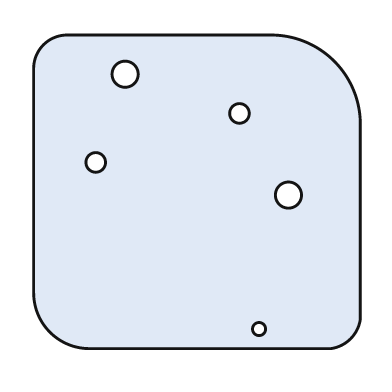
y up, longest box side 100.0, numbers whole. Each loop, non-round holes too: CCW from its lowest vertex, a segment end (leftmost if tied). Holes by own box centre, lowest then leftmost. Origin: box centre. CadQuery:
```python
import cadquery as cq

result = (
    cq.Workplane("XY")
    .moveTo(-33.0, -48.0)
    .lineTo(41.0, -48.0)
    .threePointArc((47.0, -45.0), (50.0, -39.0))
    .lineTo(50.0, 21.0)
    .threePointArc((42.0, 40.0), (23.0, 48.0))
    .lineTo(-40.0, 48.0)
    .threePointArc((-47.0, 45.0), (-50.0, 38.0))
    .lineTo(-50.0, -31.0)
    .threePointArc((-45.0, -43.0), (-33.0, -48.0))
    .close()
    .moveTo(19.0, -42.0)
    .circle(2.0)
    .moveTo(28.0, -1.0)
    .circle(4.0)
    .moveTo(-31.0, 9.0)
    .circle(3.0)
    .moveTo(13.0, 24.0)
    .circle(3.0)
    .moveTo(-22.0, 36.0)
    .circle(4.0)
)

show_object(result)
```